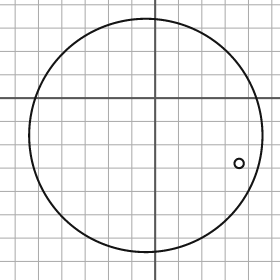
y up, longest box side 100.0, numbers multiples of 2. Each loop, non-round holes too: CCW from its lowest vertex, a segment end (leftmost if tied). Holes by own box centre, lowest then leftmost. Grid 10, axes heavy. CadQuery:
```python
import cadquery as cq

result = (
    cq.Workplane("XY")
    .moveTo(-4.0, -16.0)
    .circle(50.0)
    .moveTo(36.0, -28.0)
    .circle(2.0)
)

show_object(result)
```